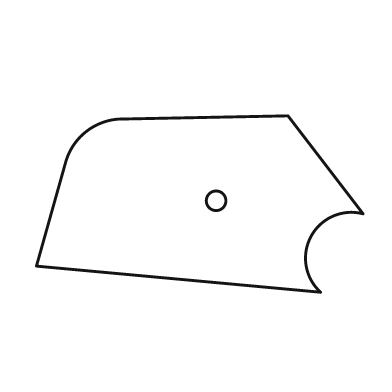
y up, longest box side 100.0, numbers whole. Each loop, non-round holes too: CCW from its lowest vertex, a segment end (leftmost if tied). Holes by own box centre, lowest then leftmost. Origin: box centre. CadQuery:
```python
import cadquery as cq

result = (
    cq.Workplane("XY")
    .moveTo(37.0, -27.0)
    .threePointArc((34.0, -10.0), (50.0, -3.0))
    .lineTo(27.0, 27.0)
    .lineTo(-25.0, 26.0)
    .threePointArc((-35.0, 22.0), (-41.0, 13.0))
    .lineTo(-50.0, -19.0)
    .close()
    .moveTo(5.0, 1.0)
    .circle(3.0)
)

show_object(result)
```